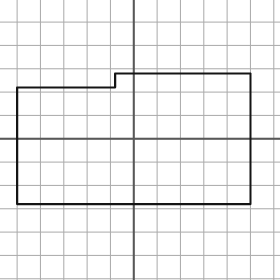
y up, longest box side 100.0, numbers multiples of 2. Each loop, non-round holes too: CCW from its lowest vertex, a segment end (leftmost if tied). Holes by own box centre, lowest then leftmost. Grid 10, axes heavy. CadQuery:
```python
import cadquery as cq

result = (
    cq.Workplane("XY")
    .moveTo(-50.0, -28.0)
    .lineTo(50.0, -28.0)
    .lineTo(50.0, 28.0)
    .lineTo(-8.0, 28.0)
    .lineTo(-8.0, 22.0)
    .lineTo(-50.0, 22.0)
    .close()
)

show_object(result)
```